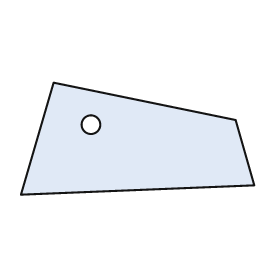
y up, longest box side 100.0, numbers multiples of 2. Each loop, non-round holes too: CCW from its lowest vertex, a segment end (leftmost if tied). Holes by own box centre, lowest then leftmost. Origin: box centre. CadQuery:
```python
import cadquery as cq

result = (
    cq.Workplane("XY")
    .moveTo(-50.0, -24.0)
    .lineTo(50.0, -20.0)
    .lineTo(42.0, 8.0)
    .lineTo(-36.0, 24.0)
    .close()
    .moveTo(-20.0, 6.0)
    .circle(4.0)
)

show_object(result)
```